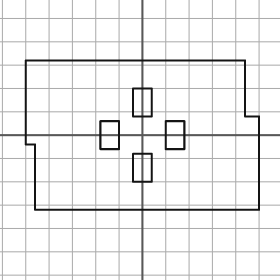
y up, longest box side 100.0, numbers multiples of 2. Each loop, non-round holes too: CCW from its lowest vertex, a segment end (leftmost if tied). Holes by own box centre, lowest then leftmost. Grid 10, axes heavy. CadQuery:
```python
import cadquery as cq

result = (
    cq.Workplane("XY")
    .moveTo(-46.0, -32.0)
    .lineTo(50.0, -32.0)
    .lineTo(50.0, 8.0)
    .lineTo(44.0, 8.0)
    .lineTo(44.0, 32.0)
    .lineTo(-50.0, 32.0)
    .lineTo(-50.0, -4.0)
    .lineTo(-46.0, -4.0)
    .close()
    .moveTo(-4.0, -20.0)
    .lineTo(4.0, -20.0)
    .lineTo(4.0, -8.0)
    .lineTo(-4.0, -8.0)
    .close()
    .moveTo(-18.0, -6.0)
    .lineTo(-10.0, -6.0)
    .lineTo(-10.0, 6.0)
    .lineTo(-18.0, 6.0)
    .close()
    .moveTo(10.0, -6.0)
    .lineTo(18.0, -6.0)
    .lineTo(18.0, 6.0)
    .lineTo(10.0, 6.0)
    .close()
    .moveTo(-4.0, 8.0)
    .lineTo(4.0, 8.0)
    .lineTo(4.0, 20.0)
    .lineTo(-4.0, 20.0)
    .close()
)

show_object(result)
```